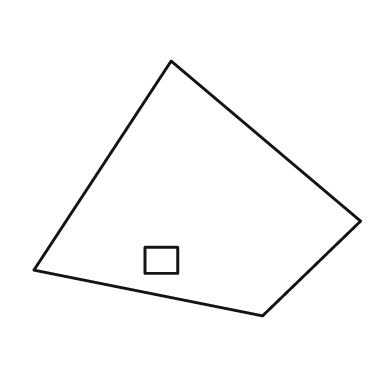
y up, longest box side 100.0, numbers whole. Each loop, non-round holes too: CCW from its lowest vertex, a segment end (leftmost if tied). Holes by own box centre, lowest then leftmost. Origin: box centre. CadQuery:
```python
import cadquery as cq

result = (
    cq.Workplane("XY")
    .moveTo(20.0, -39.0)
    .lineTo(50.0, -10.0)
    .lineTo(-8.0, 39.0)
    .lineTo(-50.0, -25.0)
    .close()
    .moveTo(-16.0, -26.0)
    .lineTo(-6.0, -26.0)
    .lineTo(-6.0, -18.0)
    .lineTo(-16.0, -18.0)
    .close()
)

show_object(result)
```